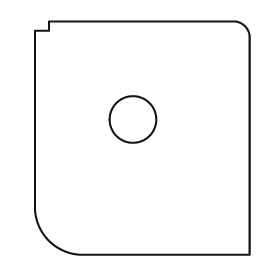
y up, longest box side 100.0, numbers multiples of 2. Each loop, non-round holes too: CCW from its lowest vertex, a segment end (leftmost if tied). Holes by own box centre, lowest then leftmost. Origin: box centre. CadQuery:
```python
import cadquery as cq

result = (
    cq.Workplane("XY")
    .moveTo(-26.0, -50.0)
    .lineTo(46.0, -50.0)
    .lineTo(46.0, 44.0)
    .threePointArc((44.0, 48.0), (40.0, 50.0))
    .lineTo(-40.0, 50.0)
    .lineTo(-40.0, 46.0)
    .lineTo(-46.0, 46.0)
    .lineTo(-46.0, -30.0)
    .threePointArc((-40.0, -44.0), (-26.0, -50.0))
    .close()
    .moveTo(-4.0, 8.0)
    .circle(10.0)
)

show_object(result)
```